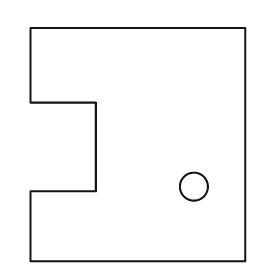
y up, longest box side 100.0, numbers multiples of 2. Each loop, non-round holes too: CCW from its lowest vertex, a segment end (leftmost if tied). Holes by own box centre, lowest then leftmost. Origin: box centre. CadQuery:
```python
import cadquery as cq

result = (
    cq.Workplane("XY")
    .moveTo(-46.0, -50.0)
    .lineTo(46.0, -50.0)
    .lineTo(46.0, 50.0)
    .lineTo(-46.0, 50.0)
    .lineTo(-46.0, 18.0)
    .lineTo(-18.0, 18.0)
    .lineTo(-18.0, -20.0)
    .lineTo(-46.0, -20.0)
    .close()
    .moveTo(24.0, -18.0)
    .circle(6.0)
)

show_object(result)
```